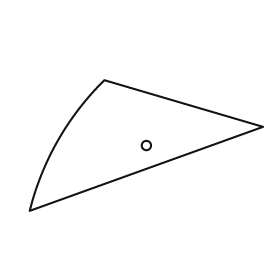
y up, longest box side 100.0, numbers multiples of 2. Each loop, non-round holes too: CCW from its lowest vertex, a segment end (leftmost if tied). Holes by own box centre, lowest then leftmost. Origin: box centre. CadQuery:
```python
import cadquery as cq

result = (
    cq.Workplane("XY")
    .moveTo(-50.0, -28.0)
    .lineTo(50.0, 8.0)
    .lineTo(-18.0, 28.0)
    .threePointArc((-38.0, 2.0), (-50.0, -28.0))
    .close()
    .moveTo(0.0, 0.0)
    .circle(2.0)
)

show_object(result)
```